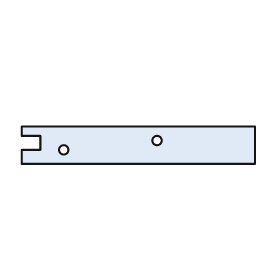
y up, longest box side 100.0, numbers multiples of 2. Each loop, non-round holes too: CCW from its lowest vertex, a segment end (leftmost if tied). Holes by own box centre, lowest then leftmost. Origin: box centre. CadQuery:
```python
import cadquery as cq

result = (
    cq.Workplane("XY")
    .moveTo(-50.0, -8.0)
    .lineTo(50.0, -8.0)
    .lineTo(50.0, 8.0)
    .lineTo(-50.0, 8.0)
    .lineTo(-50.0, 4.0)
    .lineTo(-42.0, 4.0)
    .lineTo(-42.0, -2.0)
    .lineTo(-50.0, -2.0)
    .close()
    .moveTo(-32.0, -2.0)
    .circle(2.0)
    .moveTo(8.0, 2.0)
    .circle(2.0)
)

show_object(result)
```